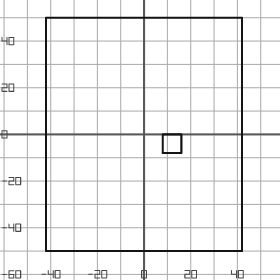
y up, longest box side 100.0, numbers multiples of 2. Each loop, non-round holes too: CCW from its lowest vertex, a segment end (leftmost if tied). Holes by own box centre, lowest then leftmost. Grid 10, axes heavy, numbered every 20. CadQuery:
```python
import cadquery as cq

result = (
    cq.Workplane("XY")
    .moveTo(-42.0, -50.0)
    .lineTo(42.0, -50.0)
    .lineTo(42.0, 50.0)
    .lineTo(-42.0, 50.0)
    .close()
    .moveTo(8.0, -8.0)
    .lineTo(16.0, -8.0)
    .lineTo(16.0, 0.0)
    .lineTo(8.0, 0.0)
    .close()
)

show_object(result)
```